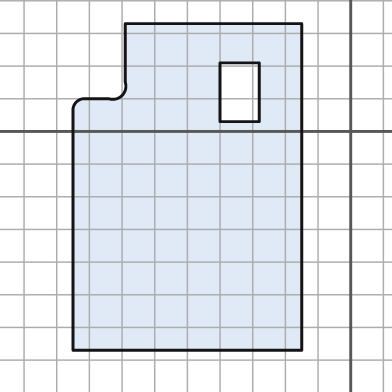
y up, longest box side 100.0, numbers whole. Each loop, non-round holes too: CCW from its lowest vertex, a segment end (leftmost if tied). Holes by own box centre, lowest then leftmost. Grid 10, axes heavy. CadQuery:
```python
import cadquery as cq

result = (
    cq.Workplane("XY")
    .moveTo(-85.0, -67.0)
    .lineTo(-15.0, -67.0)
    .lineTo(-15.0, 33.0)
    .lineTo(-69.0, 33.0)
    .lineTo(-69.0, 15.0)
    .threePointArc((-70.0, 11.0), (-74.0, 10.0))
    .lineTo(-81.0, 10.0)
    .threePointArc((-84.0, 9.0), (-85.0, 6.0))
    .close()
    .moveTo(-40.0, 3.0)
    .lineTo(-28.0, 3.0)
    .lineTo(-28.0, 21.0)
    .lineTo(-40.0, 21.0)
    .close()
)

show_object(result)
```